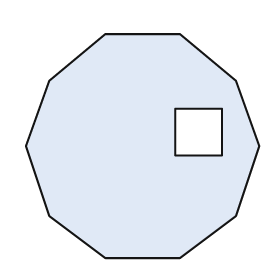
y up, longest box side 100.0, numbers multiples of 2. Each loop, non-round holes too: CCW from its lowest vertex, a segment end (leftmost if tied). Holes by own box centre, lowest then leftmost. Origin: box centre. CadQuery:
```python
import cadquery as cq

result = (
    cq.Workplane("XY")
    .moveTo(-16.0, -48.0)
    .lineTo(16.0, -48.0)
    .lineTo(40.0, -30.0)
    .lineTo(50.0, 0.0)
    .lineTo(40.0, 28.0)
    .lineTo(16.0, 48.0)
    .lineTo(-16.0, 48.0)
    .lineTo(-40.0, 28.0)
    .lineTo(-50.0, 0.0)
    .lineTo(-40.0, -30.0)
    .close()
    .moveTo(14.0, -4.0)
    .lineTo(34.0, -4.0)
    .lineTo(34.0, 16.0)
    .lineTo(14.0, 16.0)
    .close()
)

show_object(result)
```